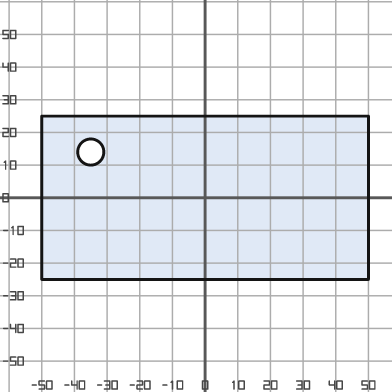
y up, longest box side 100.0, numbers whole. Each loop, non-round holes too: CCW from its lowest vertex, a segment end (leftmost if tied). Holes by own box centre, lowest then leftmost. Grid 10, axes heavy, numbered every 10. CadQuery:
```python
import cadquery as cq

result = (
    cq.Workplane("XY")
    .moveTo(-50.0, -25.0)
    .lineTo(50.0, -25.0)
    .lineTo(50.0, 25.0)
    .lineTo(-50.0, 25.0)
    .close()
    .moveTo(-35.0, 14.0)
    .circle(4.0)
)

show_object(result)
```